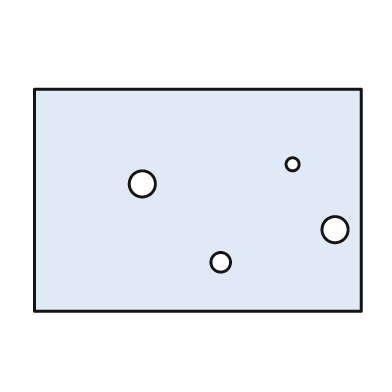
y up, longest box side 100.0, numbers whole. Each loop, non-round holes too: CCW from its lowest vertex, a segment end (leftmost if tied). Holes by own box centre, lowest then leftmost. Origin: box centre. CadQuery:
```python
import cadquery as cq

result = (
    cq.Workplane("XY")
    .moveTo(-50.0, -34.0)
    .lineTo(50.0, -34.0)
    .lineTo(50.0, 34.0)
    .lineTo(-50.0, 34.0)
    .close()
    .moveTo(7.0, -19.0)
    .circle(3.0)
    .moveTo(42.0, -9.0)
    .circle(4.0)
    .moveTo(-17.0, 5.0)
    .circle(4.0)
    .moveTo(29.0, 11.0)
    .circle(2.0)
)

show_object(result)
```